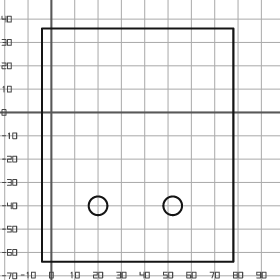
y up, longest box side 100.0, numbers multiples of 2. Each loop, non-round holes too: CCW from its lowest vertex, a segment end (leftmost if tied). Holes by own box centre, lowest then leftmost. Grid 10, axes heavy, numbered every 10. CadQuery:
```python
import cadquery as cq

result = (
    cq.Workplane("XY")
    .moveTo(-4.0, -64.0)
    .lineTo(78.0, -64.0)
    .lineTo(78.0, 36.0)
    .lineTo(-4.0, 36.0)
    .close()
    .moveTo(20.0, -40.0)
    .circle(4.0)
    .moveTo(52.0, -40.0)
    .circle(4.0)
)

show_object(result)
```